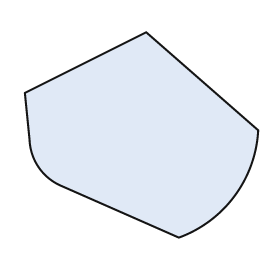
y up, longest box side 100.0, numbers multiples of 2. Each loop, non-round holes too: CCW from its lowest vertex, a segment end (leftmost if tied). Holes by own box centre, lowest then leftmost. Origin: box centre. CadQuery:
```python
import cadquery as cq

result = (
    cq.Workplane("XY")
    .moveTo(16.0, -44.0)
    .threePointArc((40.0, -26.0), (50.0, 2.0))
    .lineTo(2.0, 44.0)
    .lineTo(-50.0, 18.0)
    .lineTo(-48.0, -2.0)
    .threePointArc((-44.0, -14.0), (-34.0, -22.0))
    .close()
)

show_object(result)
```